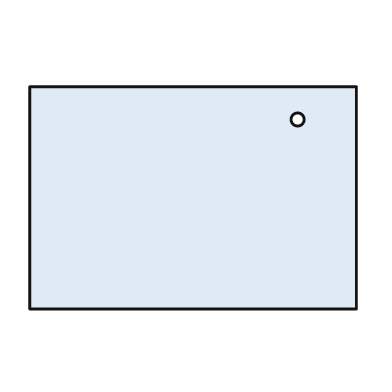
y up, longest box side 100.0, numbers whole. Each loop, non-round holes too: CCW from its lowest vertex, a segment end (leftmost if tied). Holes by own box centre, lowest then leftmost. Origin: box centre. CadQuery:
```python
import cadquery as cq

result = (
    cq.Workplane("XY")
    .moveTo(-50.0, -34.0)
    .lineTo(50.0, -34.0)
    .lineTo(50.0, 34.0)
    .lineTo(-50.0, 34.0)
    .close()
    .moveTo(32.0, 24.0)
    .circle(2.0)
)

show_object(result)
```